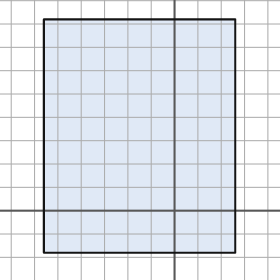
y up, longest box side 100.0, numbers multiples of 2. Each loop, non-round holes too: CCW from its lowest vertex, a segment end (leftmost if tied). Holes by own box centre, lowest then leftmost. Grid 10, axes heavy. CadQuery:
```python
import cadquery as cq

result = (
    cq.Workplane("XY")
    .moveTo(-56.0, -18.0)
    .lineTo(26.0, -18.0)
    .lineTo(26.0, 82.0)
    .lineTo(-56.0, 82.0)
    .close()
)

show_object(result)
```